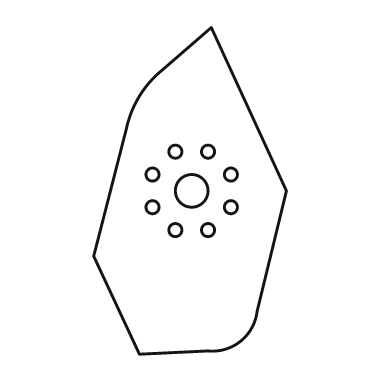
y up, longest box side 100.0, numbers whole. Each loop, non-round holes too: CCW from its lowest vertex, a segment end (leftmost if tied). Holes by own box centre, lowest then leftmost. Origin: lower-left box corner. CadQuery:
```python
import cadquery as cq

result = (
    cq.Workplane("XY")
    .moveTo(14.0, 0.0)
    .lineTo(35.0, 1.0)
    .threePointArc((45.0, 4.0), (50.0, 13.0))
    .lineTo(59.0, 50.0)
    .lineTo(36.0, 100.0)
    .lineTo(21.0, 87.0)
    .threePointArc((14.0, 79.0), (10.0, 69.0))
    .lineTo(0.0, 30.0)
    .close()
    .moveTo(25.0, 38.0)
    .circle(2.0)
    .moveTo(35.0, 38.0)
    .circle(2.0)
    .moveTo(18.0, 45.0)
    .circle(2.0)
    .moveTo(42.0, 45.0)
    .circle(2.0)
    .moveTo(30.0, 50.0)
    .circle(5.0)
    .moveTo(18.0, 55.0)
    .circle(2.0)
    .moveTo(42.0, 55.0)
    .circle(2.0)
    .moveTo(25.0, 62.0)
    .circle(2.0)
    .moveTo(35.0, 62.0)
    .circle(2.0)
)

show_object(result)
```